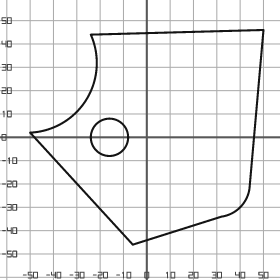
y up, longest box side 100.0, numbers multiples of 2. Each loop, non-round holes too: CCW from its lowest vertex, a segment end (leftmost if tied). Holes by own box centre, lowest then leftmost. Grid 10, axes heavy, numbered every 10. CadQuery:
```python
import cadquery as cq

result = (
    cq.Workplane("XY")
    .moveTo(-6.0, -46.0)
    .lineTo(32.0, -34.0)
    .threePointArc((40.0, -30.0), (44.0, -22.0))
    .lineTo(50.0, 46.0)
    .lineTo(-24.0, 44.0)
    .threePointArc((-26.0, 16.0), (-50.0, 2.0))
    .close()
    .moveTo(-16.0, 0.0)
    .circle(8.0)
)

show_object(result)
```